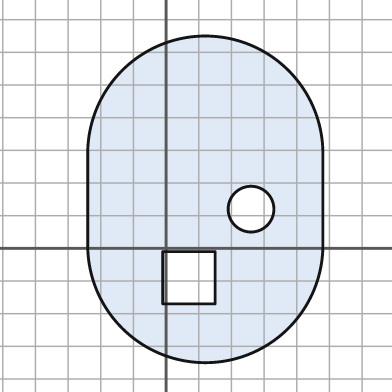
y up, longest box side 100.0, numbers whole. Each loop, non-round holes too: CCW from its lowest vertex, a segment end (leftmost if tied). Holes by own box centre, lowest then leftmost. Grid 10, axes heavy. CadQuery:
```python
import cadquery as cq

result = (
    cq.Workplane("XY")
    .moveTo(-24.0, 1.0)
    .threePointArc((12.0, -35.0), (48.0, 1.0))
    .lineTo(48.0, 29.0)
    .threePointArc((12.0, 65.0), (-24.0, 29.0))
    .close()
    .moveTo(-1.0, -17.0)
    .lineTo(15.0, -17.0)
    .lineTo(15.0, -1.0)
    .lineTo(-1.0, -1.0)
    .close()
    .moveTo(26.0, 12.0)
    .circle(7.0)
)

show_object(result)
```